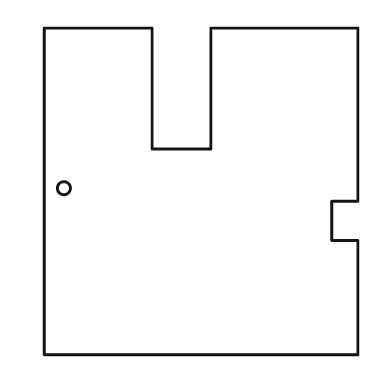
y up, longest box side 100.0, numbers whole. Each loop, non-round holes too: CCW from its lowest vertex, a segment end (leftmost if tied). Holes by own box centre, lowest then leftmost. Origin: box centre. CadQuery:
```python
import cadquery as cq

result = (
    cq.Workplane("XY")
    .moveTo(-48.0, -50.0)
    .lineTo(48.0, -50.0)
    .lineTo(48.0, -15.0)
    .lineTo(40.0, -15.0)
    .lineTo(40.0, -3.0)
    .lineTo(48.0, -3.0)
    .lineTo(48.0, 50.0)
    .lineTo(3.0, 50.0)
    .lineTo(3.0, 13.0)
    .lineTo(-15.0, 13.0)
    .lineTo(-15.0, 50.0)
    .lineTo(-48.0, 50.0)
    .close()
    .moveTo(-42.0, 1.0)
    .circle(2.0)
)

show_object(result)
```